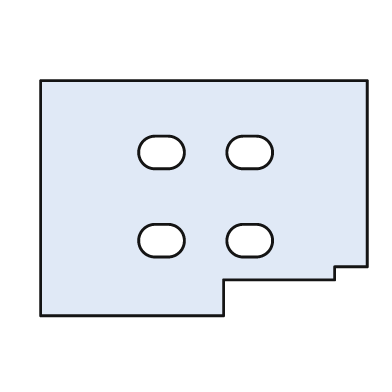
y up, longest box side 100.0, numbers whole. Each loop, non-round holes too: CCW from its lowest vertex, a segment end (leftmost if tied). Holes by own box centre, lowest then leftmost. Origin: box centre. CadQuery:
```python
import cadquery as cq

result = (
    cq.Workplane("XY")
    .moveTo(-50.0, -36.0)
    .lineTo(6.0, -36.0)
    .lineTo(6.0, -25.0)
    .lineTo(40.0, -25.0)
    .lineTo(40.0, -21.0)
    .lineTo(50.0, -21.0)
    .lineTo(50.0, 36.0)
    .lineTo(-50.0, 36.0)
    .close()
    .moveTo(-15.0, -18.0)
    .lineTo(-11.0, -18.0)
    .threePointArc((-6.0, -13.0), (-11.0, -8.0))
    .lineTo(-15.0, -8.0)
    .threePointArc((-20.0, -13.0), (-15.0, -18.0))
    .close()
    .moveTo(12.0, -18.0)
    .lineTo(16.0, -18.0)
    .threePointArc((21.0, -13.0), (16.0, -8.0))
    .lineTo(12.0, -8.0)
    .threePointArc((7.0, -13.0), (12.0, -18.0))
    .close()
    .moveTo(-15.0, 9.0)
    .lineTo(-11.0, 9.0)
    .threePointArc((-6.0, 14.0), (-11.0, 19.0))
    .lineTo(-15.0, 19.0)
    .threePointArc((-20.0, 14.0), (-15.0, 9.0))
    .close()
    .moveTo(12.0, 9.0)
    .lineTo(16.0, 9.0)
    .threePointArc((21.0, 14.0), (16.0, 19.0))
    .lineTo(12.0, 19.0)
    .threePointArc((7.0, 14.0), (12.0, 9.0))
    .close()
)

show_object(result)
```